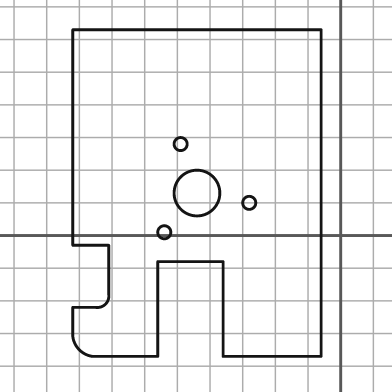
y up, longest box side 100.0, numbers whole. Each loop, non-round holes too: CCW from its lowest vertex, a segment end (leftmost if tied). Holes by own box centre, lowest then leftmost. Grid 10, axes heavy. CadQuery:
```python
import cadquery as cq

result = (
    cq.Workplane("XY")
    .moveTo(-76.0, -37.0)
    .lineTo(-56.0, -37.0)
    .lineTo(-56.0, -8.0)
    .lineTo(-36.0, -8.0)
    .lineTo(-36.0, -37.0)
    .lineTo(-6.0, -37.0)
    .lineTo(-6.0, 63.0)
    .lineTo(-82.0, 63.0)
    .lineTo(-82.0, -3.0)
    .lineTo(-71.0, -3.0)
    .lineTo(-71.0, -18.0)
    .threePointArc((-72.0, -21.0), (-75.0, -22.0))
    .lineTo(-82.0, -22.0)
    .lineTo(-82.0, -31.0)
    .threePointArc((-80.0, -35.0), (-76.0, -37.0))
    .close()
    .moveTo(-54.0, 1.0)
    .circle(2.0)
    .moveTo(-28.0, 10.0)
    .circle(2.0)
    .moveTo(-44.0, 13.0)
    .circle(7.0)
    .moveTo(-49.0, 28.0)
    .circle(2.0)
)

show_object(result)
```